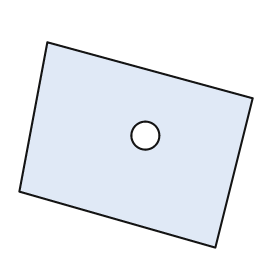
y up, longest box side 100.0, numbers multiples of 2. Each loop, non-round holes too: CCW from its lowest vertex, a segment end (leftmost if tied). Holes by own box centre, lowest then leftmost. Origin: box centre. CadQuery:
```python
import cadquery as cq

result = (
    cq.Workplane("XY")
    .moveTo(34.0, -44.0)
    .lineTo(50.0, 20.0)
    .lineTo(-38.0, 44.0)
    .lineTo(-50.0, -20.0)
    .close()
    .moveTo(4.0, 4.0)
    .circle(6.0)
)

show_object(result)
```